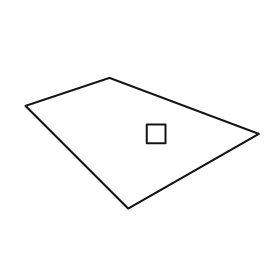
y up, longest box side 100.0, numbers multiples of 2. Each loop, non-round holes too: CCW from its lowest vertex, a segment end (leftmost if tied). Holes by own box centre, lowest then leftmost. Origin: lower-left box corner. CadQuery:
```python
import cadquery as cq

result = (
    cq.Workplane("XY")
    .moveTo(44.0, 0.0)
    .lineTo(100.0, 32.0)
    .lineTo(36.0, 56.0)
    .lineTo(0.0, 44.0)
    .close()
    .moveTo(52.0, 28.0)
    .lineTo(60.0, 28.0)
    .lineTo(60.0, 36.0)
    .lineTo(52.0, 36.0)
    .close()
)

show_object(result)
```